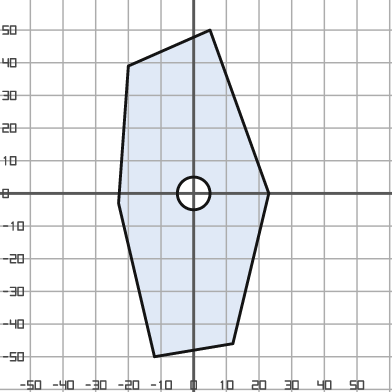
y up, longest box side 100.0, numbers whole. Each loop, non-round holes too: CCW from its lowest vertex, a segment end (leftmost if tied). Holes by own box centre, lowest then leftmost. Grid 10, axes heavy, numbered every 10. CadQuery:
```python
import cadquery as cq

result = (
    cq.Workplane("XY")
    .moveTo(-12.0, -50.0)
    .lineTo(12.0, -46.0)
    .lineTo(23.0, 0.0)
    .lineTo(5.0, 50.0)
    .lineTo(-20.0, 39.0)
    .lineTo(-23.0, -3.0)
    .close()
    .moveTo(0.0, 0.0)
    .circle(5.0)
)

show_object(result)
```